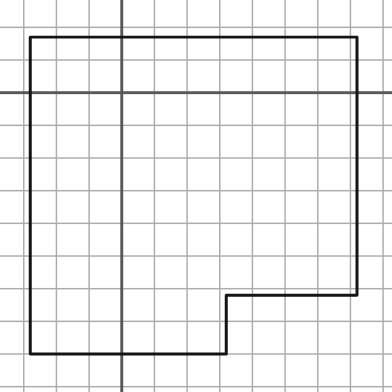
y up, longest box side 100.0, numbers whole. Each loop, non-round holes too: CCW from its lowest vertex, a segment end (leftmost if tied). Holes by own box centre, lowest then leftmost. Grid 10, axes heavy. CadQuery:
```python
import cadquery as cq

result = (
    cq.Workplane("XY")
    .moveTo(-28.0, -80.0)
    .lineTo(32.0, -80.0)
    .lineTo(32.0, -62.0)
    .lineTo(72.0, -62.0)
    .lineTo(72.0, 17.0)
    .lineTo(-28.0, 17.0)
    .close()
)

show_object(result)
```